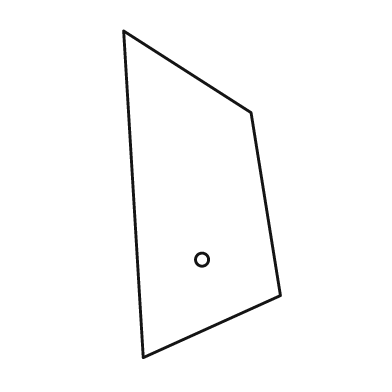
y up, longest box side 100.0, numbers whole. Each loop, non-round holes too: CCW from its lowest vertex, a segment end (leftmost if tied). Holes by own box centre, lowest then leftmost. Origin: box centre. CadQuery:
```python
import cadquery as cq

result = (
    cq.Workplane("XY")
    .moveTo(-18.0, -50.0)
    .lineTo(24.0, -31.0)
    .lineTo(15.0, 25.0)
    .lineTo(-24.0, 50.0)
    .close()
    .moveTo(0.0, -20.0)
    .circle(2.0)
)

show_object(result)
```